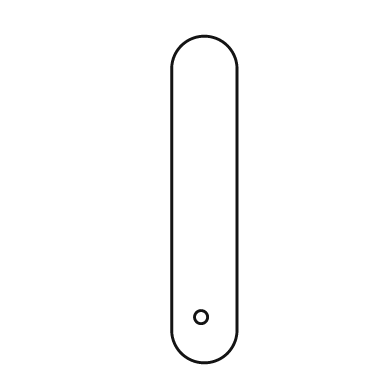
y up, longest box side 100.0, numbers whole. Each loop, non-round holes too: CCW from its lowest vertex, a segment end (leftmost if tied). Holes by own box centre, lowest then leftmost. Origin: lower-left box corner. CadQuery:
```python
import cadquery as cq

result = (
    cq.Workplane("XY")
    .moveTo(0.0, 10.0)
    .threePointArc((10.0, 0.0), (20.0, 10.0))
    .lineTo(20.0, 90.0)
    .threePointArc((10.0, 100.0), (0.0, 90.0))
    .close()
    .moveTo(9.0, 14.0)
    .circle(2.0)
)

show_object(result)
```